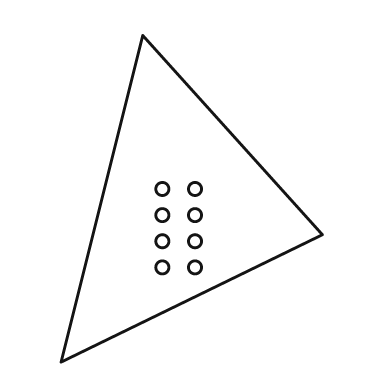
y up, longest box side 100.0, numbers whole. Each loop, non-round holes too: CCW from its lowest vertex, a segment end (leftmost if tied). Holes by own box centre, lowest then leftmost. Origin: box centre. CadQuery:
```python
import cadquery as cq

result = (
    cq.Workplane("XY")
    .moveTo(-40.0, -50.0)
    .lineTo(40.0, -11.0)
    .lineTo(-15.0, 50.0)
    .close()
    .moveTo(-9.0, -21.0)
    .circle(2.0)
    .moveTo(1.0, -21.0)
    .circle(2.0)
    .moveTo(-9.0, -13.0)
    .circle(2.0)
    .moveTo(1.0, -13.0)
    .circle(2.0)
    .moveTo(-9.0, -5.0)
    .circle(2.0)
    .moveTo(1.0, -5.0)
    .circle(2.0)
    .moveTo(-9.0, 3.0)
    .circle(2.0)
    .moveTo(1.0, 3.0)
    .circle(2.0)
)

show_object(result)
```